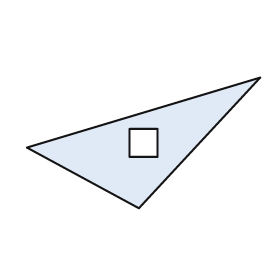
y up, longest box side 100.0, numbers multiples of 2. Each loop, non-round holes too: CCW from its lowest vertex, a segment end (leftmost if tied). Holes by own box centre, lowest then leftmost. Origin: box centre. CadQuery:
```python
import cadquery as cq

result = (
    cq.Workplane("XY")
    .moveTo(-2.0, -28.0)
    .lineTo(50.0, 28.0)
    .lineTo(-50.0, -2.0)
    .close()
    .moveTo(-6.0, -6.0)
    .lineTo(6.0, -6.0)
    .lineTo(6.0, 6.0)
    .lineTo(-6.0, 6.0)
    .close()
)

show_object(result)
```